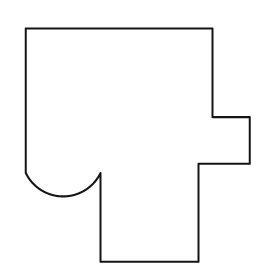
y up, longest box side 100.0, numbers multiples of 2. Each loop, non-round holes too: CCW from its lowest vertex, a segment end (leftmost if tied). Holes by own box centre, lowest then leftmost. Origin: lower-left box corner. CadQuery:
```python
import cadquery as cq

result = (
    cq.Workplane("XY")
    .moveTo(32.0, 0.0)
    .lineTo(74.0, 0.0)
    .lineTo(74.0, 42.0)
    .lineTo(96.0, 42.0)
    .lineTo(96.0, 62.0)
    .lineTo(80.0, 62.0)
    .lineTo(80.0, 100.0)
    .lineTo(0.0, 100.0)
    .lineTo(0.0, 38.0)
    .threePointArc((16.0, 28.0), (32.0, 38.0))
    .close()
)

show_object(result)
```